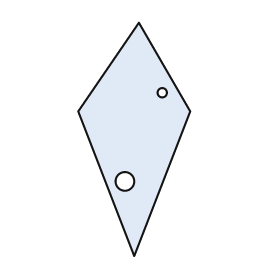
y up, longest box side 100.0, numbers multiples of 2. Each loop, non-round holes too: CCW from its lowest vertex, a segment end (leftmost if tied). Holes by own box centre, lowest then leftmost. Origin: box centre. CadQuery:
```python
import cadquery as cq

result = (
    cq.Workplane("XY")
    .moveTo(0.0, -50.0)
    .lineTo(24.0, 12.0)
    .lineTo(2.0, 50.0)
    .lineTo(-24.0, 12.0)
    .close()
    .moveTo(-4.0, -18.0)
    .circle(4.0)
    .moveTo(12.0, 20.0)
    .circle(2.0)
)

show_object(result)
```